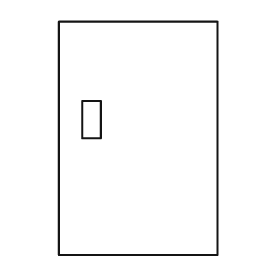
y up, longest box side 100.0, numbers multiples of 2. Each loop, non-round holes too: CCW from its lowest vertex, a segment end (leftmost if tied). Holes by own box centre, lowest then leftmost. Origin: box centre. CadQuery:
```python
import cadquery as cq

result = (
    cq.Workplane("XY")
    .moveTo(-34.0, -50.0)
    .lineTo(34.0, -50.0)
    .lineTo(34.0, 50.0)
    .lineTo(-34.0, 50.0)
    .close()
    .moveTo(-24.0, 0.0)
    .lineTo(-16.0, 0.0)
    .lineTo(-16.0, 16.0)
    .lineTo(-24.0, 16.0)
    .close()
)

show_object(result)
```